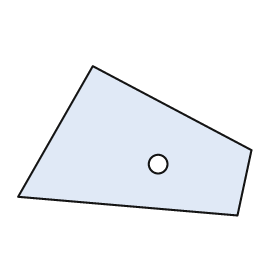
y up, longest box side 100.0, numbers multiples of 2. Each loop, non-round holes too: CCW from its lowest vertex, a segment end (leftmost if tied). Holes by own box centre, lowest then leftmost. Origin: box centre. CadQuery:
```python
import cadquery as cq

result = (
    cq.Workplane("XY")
    .moveTo(44.0, -32.0)
    .lineTo(50.0, -4.0)
    .lineTo(-18.0, 32.0)
    .lineTo(-50.0, -24.0)
    .close()
    .moveTo(10.0, -10.0)
    .circle(4.0)
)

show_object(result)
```